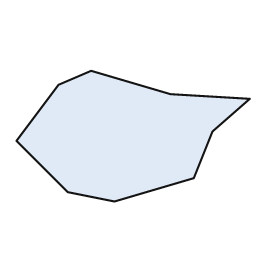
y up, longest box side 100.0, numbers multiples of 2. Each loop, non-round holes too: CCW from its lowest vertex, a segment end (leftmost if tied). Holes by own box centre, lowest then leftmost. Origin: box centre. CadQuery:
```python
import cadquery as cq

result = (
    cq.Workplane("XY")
    .moveTo(-8.0, -28.0)
    .lineTo(26.0, -18.0)
    .lineTo(34.0, 2.0)
    .lineTo(50.0, 16.0)
    .lineTo(16.0, 18.0)
    .lineTo(-18.0, 28.0)
    .lineTo(-32.0, 22.0)
    .lineTo(-50.0, -2.0)
    .lineTo(-28.0, -24.0)
    .close()
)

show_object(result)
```